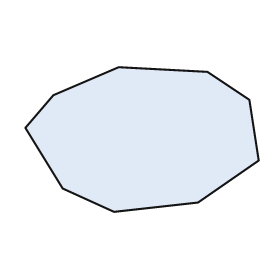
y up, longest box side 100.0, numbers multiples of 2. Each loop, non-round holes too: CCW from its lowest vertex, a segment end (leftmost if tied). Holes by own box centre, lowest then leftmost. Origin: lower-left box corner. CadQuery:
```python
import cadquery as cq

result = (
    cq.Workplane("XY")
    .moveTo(38.0, 0.0)
    .lineTo(74.0, 4.0)
    .lineTo(100.0, 22.0)
    .lineTo(96.0, 48.0)
    .lineTo(78.0, 60.0)
    .lineTo(40.0, 62.0)
    .lineTo(12.0, 50.0)
    .lineTo(0.0, 36.0)
    .lineTo(16.0, 10.0)
    .close()
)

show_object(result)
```